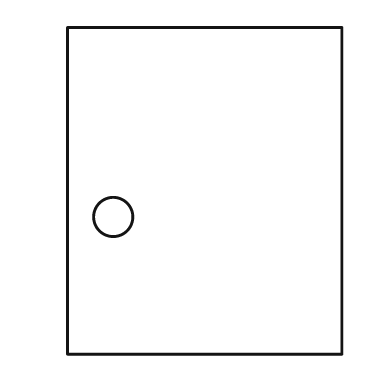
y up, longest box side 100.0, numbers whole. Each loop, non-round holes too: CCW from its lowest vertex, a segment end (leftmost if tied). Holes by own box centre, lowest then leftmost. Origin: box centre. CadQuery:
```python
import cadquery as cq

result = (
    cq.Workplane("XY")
    .moveTo(-42.0, -50.0)
    .lineTo(42.0, -50.0)
    .lineTo(42.0, 50.0)
    .lineTo(-42.0, 50.0)
    .close()
    .moveTo(-28.0, -8.0)
    .circle(6.0)
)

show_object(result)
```